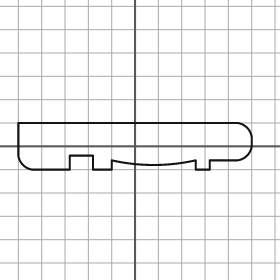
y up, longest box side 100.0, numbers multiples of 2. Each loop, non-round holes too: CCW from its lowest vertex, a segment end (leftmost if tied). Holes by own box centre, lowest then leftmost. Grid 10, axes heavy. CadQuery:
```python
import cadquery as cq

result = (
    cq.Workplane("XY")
    .moveTo(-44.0, -10.0)
    .lineTo(-28.0, -10.0)
    .lineTo(-28.0, -4.0)
    .lineTo(-18.0, -4.0)
    .lineTo(-18.0, -10.0)
    .lineTo(-10.0, -10.0)
    .lineTo(-10.0, -6.0)
    .threePointArc((8.0, -8.0), (26.0, -6.0))
    .lineTo(26.0, -10.0)
    .lineTo(32.0, -10.0)
    .lineTo(32.0, -6.0)
    .lineTo(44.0, -6.0)
    .threePointArc((48.0, -4.0), (50.0, 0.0))
    .lineTo(50.0, 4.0)
    .threePointArc((48.0, 8.0), (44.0, 10.0))
    .lineTo(-50.0, 10.0)
    .lineTo(-50.0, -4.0)
    .threePointArc((-48.0, -8.0), (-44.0, -10.0))
    .close()
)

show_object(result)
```